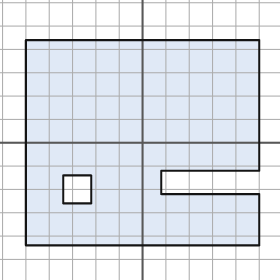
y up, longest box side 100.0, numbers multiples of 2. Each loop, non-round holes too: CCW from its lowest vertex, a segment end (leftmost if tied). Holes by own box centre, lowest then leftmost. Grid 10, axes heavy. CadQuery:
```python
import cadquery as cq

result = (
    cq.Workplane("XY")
    .moveTo(-50.0, -44.0)
    .lineTo(50.0, -44.0)
    .lineTo(50.0, -22.0)
    .lineTo(8.0, -22.0)
    .lineTo(8.0, -12.0)
    .lineTo(50.0, -12.0)
    .lineTo(50.0, 44.0)
    .lineTo(-50.0, 44.0)
    .close()
    .moveTo(-34.0, -26.0)
    .lineTo(-22.0, -26.0)
    .lineTo(-22.0, -14.0)
    .lineTo(-34.0, -14.0)
    .close()
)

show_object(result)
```